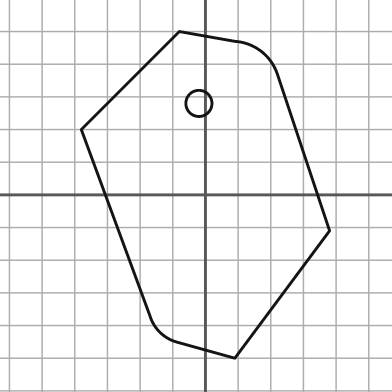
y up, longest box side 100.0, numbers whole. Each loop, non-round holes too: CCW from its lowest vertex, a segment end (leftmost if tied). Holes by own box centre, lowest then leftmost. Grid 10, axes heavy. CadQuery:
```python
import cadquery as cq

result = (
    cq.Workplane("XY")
    .moveTo(9.0, -50.0)
    .lineTo(38.0, -11.0)
    .lineTo(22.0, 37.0)
    .threePointArc((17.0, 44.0), (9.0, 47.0))
    .lineTo(-8.0, 50.0)
    .lineTo(-38.0, 20.0)
    .lineTo(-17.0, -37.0)
    .threePointArc((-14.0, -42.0), (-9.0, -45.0))
    .close()
    .moveTo(-2.0, 28.0)
    .circle(4.0)
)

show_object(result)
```